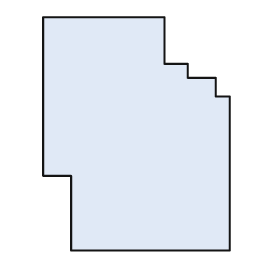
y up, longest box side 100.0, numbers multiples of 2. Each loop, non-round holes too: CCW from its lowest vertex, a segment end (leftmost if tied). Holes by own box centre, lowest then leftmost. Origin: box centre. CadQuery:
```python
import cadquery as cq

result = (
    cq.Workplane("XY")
    .moveTo(-28.0, -50.0)
    .lineTo(40.0, -50.0)
    .lineTo(40.0, 16.0)
    .lineTo(34.0, 16.0)
    .lineTo(34.0, 24.0)
    .lineTo(22.0, 24.0)
    .lineTo(22.0, 30.0)
    .lineTo(12.0, 30.0)
    .lineTo(12.0, 50.0)
    .lineTo(-40.0, 50.0)
    .lineTo(-40.0, -18.0)
    .lineTo(-28.0, -18.0)
    .close()
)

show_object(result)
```